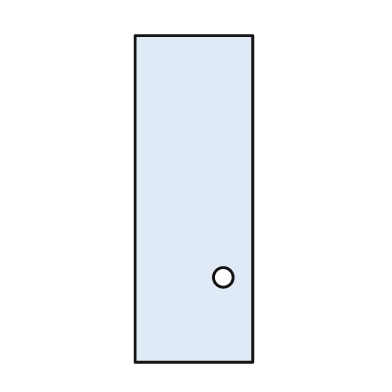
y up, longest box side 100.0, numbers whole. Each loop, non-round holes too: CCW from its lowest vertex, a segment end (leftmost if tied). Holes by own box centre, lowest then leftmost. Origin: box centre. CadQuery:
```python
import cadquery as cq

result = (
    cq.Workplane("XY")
    .moveTo(-18.0, -50.0)
    .lineTo(18.0, -50.0)
    .lineTo(18.0, 50.0)
    .lineTo(-18.0, 50.0)
    .close()
    .moveTo(9.0, -24.0)
    .circle(3.0)
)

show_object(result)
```